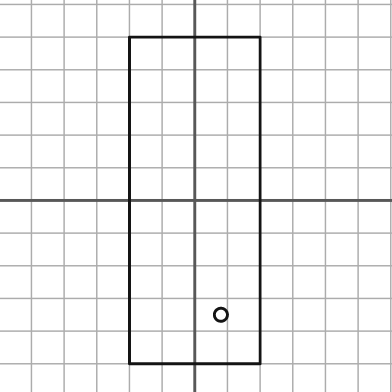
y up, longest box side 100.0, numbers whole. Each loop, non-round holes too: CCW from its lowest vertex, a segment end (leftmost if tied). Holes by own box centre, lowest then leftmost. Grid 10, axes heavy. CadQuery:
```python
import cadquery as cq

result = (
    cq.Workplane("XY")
    .moveTo(-20.0, -50.0)
    .lineTo(20.0, -50.0)
    .lineTo(20.0, 50.0)
    .lineTo(-20.0, 50.0)
    .close()
    .moveTo(8.0, -35.0)
    .circle(2.0)
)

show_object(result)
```